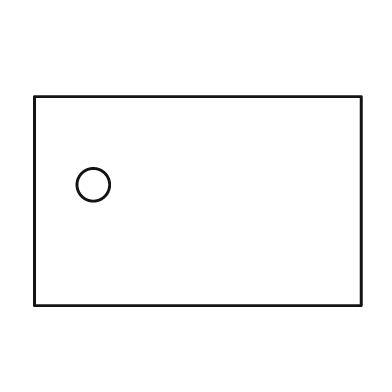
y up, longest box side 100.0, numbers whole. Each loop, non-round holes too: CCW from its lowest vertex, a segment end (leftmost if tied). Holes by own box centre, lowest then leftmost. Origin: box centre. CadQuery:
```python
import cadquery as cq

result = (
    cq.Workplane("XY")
    .moveTo(-50.0, -32.0)
    .lineTo(50.0, -32.0)
    .lineTo(50.0, 32.0)
    .lineTo(-50.0, 32.0)
    .close()
    .moveTo(-32.0, 5.0)
    .circle(5.0)
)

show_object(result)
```